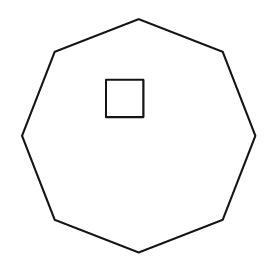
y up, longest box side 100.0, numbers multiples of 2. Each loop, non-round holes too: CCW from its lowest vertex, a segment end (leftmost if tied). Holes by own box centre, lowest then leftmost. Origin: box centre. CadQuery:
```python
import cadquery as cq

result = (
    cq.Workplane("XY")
    .moveTo(0.0, -50.0)
    .lineTo(36.0, -36.0)
    .lineTo(50.0, 0.0)
    .lineTo(36.0, 36.0)
    .lineTo(0.0, 50.0)
    .lineTo(-36.0, 36.0)
    .lineTo(-50.0, 0.0)
    .lineTo(-36.0, -36.0)
    .close()
    .moveTo(-14.0, 8.0)
    .lineTo(2.0, 8.0)
    .lineTo(2.0, 24.0)
    .lineTo(-14.0, 24.0)
    .close()
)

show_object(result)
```